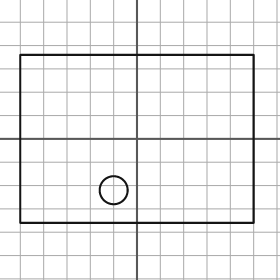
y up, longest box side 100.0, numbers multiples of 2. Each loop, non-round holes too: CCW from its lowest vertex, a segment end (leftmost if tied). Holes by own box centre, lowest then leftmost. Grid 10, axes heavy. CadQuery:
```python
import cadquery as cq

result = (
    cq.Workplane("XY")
    .moveTo(-50.0, -36.0)
    .lineTo(50.0, -36.0)
    .lineTo(50.0, 36.0)
    .lineTo(-50.0, 36.0)
    .close()
    .moveTo(-10.0, -22.0)
    .circle(6.0)
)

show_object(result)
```